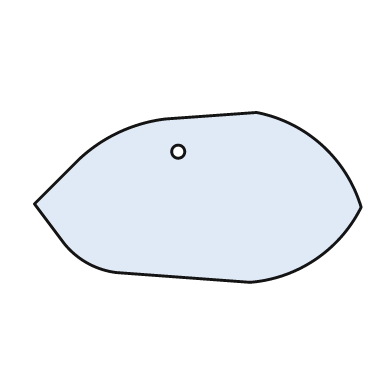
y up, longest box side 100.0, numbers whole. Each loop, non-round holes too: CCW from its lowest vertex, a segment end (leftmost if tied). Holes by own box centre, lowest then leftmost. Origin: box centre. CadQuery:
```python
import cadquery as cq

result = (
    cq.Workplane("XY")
    .moveTo(16.0, -26.0)
    .threePointArc((36.0, -19.0), (50.0, -3.0))
    .threePointArc((38.0, 16.0), (18.0, 26.0))
    .lineTo(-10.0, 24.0)
    .threePointArc((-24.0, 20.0), (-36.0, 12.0))
    .lineTo(-50.0, -2.0)
    .lineTo(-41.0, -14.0)
    .threePointArc((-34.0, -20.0), (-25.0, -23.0))
    .close()
    .moveTo(-6.0, 14.0)
    .circle(2.0)
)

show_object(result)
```